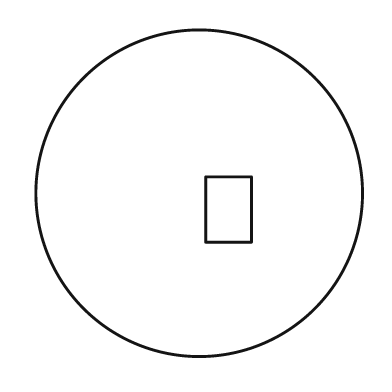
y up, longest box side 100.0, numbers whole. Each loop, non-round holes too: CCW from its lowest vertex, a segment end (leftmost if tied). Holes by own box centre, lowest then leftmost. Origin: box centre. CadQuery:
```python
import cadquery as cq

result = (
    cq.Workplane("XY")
    .moveTo(0.0, 0.0)
    .circle(50.0)
    .moveTo(2.0, -15.0)
    .lineTo(16.0, -15.0)
    .lineTo(16.0, 5.0)
    .lineTo(2.0, 5.0)
    .close()
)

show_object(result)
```